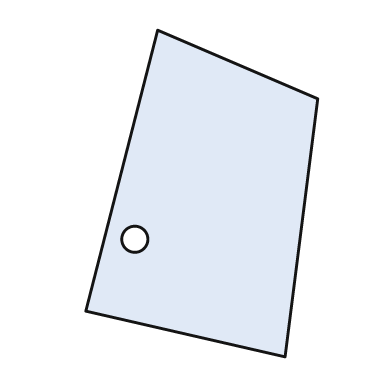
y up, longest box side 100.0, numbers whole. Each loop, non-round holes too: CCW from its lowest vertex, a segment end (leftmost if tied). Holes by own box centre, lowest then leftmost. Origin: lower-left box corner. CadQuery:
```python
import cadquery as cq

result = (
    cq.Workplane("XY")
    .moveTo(61.0, 0.0)
    .lineTo(71.0, 79.0)
    .lineTo(22.0, 100.0)
    .lineTo(0.0, 14.0)
    .close()
    .moveTo(15.0, 36.0)
    .circle(4.0)
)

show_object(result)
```